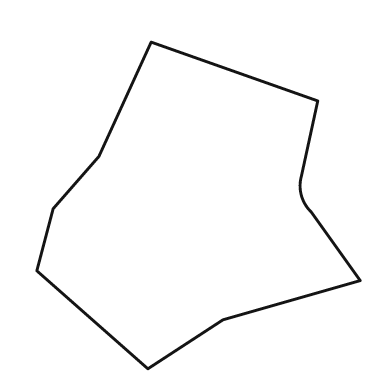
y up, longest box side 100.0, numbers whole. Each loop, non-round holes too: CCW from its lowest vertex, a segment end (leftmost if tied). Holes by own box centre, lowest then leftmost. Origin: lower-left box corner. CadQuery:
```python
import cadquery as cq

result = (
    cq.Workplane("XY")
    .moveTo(34.0, 0.0)
    .lineTo(57.0, 15.0)
    .lineTo(99.0, 27.0)
    .lineTo(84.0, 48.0)
    .threePointArc((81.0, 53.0), (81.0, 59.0))
    .lineTo(86.0, 82.0)
    .lineTo(35.0, 100.0)
    .lineTo(19.0, 65.0)
    .lineTo(5.0, 49.0)
    .lineTo(0.0, 30.0)
    .close()
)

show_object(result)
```